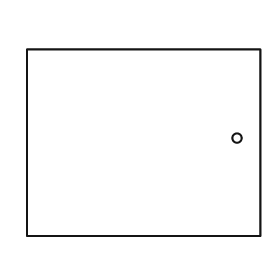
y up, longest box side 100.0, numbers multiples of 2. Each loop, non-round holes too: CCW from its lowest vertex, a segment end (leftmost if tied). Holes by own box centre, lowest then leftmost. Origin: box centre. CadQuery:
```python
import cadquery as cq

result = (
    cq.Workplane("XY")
    .moveTo(-50.0, -40.0)
    .lineTo(50.0, -40.0)
    .lineTo(50.0, 40.0)
    .lineTo(-50.0, 40.0)
    .close()
    .moveTo(40.0, 2.0)
    .circle(2.0)
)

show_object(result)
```